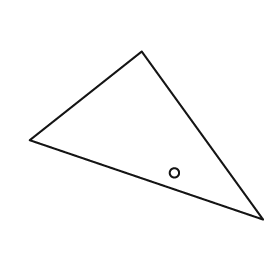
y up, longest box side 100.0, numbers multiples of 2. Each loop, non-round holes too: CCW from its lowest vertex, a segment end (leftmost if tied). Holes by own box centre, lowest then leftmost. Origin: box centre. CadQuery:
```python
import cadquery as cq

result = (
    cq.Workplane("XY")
    .moveTo(50.0, -36.0)
    .lineTo(-2.0, 36.0)
    .lineTo(-50.0, -2.0)
    .close()
    .moveTo(12.0, -16.0)
    .circle(2.0)
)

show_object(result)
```